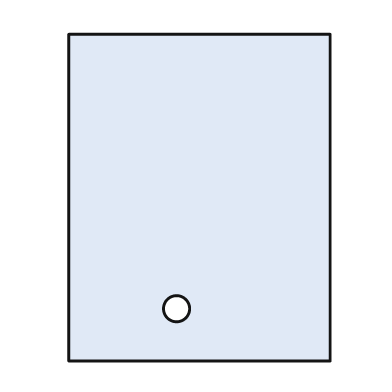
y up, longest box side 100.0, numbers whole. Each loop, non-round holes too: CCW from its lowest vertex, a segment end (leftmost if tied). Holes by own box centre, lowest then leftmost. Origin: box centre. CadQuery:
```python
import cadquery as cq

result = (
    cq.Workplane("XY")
    .moveTo(-40.0, -50.0)
    .lineTo(40.0, -50.0)
    .lineTo(40.0, 50.0)
    .lineTo(-40.0, 50.0)
    .close()
    .moveTo(-7.0, -34.0)
    .circle(4.0)
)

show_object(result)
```